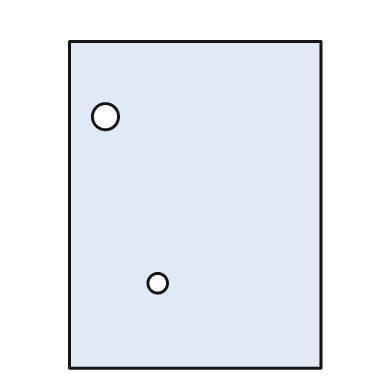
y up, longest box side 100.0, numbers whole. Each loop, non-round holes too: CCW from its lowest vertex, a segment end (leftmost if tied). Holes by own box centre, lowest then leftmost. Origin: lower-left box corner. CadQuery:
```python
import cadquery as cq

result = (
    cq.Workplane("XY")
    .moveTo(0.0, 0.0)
    .lineTo(77.0, 0.0)
    .lineTo(77.0, 100.0)
    .lineTo(0.0, 100.0)
    .close()
    .moveTo(27.0, 26.0)
    .circle(3.0)
    .moveTo(11.0, 77.0)
    .circle(4.0)
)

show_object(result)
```